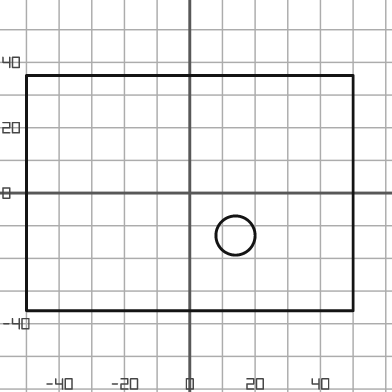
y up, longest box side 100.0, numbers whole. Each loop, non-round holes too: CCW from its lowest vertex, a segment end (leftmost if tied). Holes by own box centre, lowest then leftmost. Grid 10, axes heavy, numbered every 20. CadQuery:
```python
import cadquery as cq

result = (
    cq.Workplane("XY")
    .moveTo(-50.0, -36.0)
    .lineTo(50.0, -36.0)
    .lineTo(50.0, 36.0)
    .lineTo(-50.0, 36.0)
    .close()
    .moveTo(14.0, -13.0)
    .circle(6.0)
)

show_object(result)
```